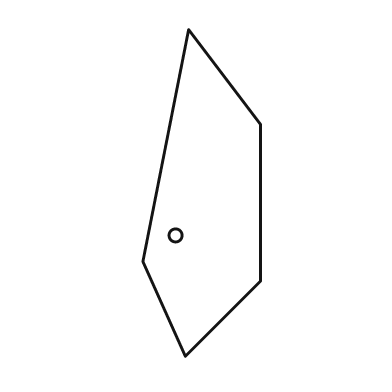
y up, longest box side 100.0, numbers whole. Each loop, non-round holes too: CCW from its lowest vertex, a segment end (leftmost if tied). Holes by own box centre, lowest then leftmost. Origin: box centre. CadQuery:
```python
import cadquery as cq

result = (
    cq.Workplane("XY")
    .moveTo(-5.0, -50.0)
    .lineTo(18.0, -27.0)
    .lineTo(18.0, 21.0)
    .lineTo(-4.0, 50.0)
    .lineTo(-18.0, -21.0)
    .close()
    .moveTo(-8.0, -13.0)
    .circle(2.0)
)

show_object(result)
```